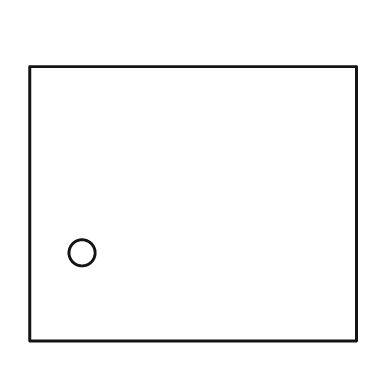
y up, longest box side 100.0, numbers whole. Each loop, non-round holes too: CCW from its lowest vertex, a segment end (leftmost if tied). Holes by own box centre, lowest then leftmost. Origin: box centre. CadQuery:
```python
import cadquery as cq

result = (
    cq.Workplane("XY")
    .moveTo(-50.0, -42.0)
    .lineTo(50.0, -42.0)
    .lineTo(50.0, 42.0)
    .lineTo(-50.0, 42.0)
    .close()
    .moveTo(-34.0, -15.0)
    .circle(4.0)
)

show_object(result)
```